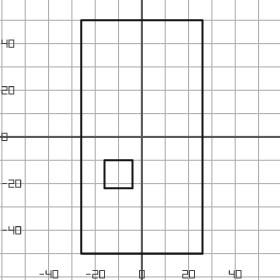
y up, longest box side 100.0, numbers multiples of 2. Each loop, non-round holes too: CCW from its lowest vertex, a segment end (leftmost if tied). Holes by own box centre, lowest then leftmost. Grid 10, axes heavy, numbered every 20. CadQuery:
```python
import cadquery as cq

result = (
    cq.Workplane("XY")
    .moveTo(-26.0, -50.0)
    .lineTo(26.0, -50.0)
    .lineTo(26.0, 50.0)
    .lineTo(-26.0, 50.0)
    .close()
    .moveTo(-16.0, -22.0)
    .lineTo(-4.0, -22.0)
    .lineTo(-4.0, -10.0)
    .lineTo(-16.0, -10.0)
    .close()
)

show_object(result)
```